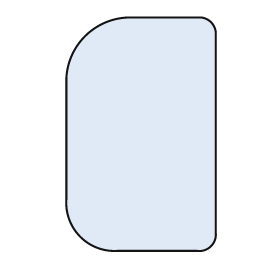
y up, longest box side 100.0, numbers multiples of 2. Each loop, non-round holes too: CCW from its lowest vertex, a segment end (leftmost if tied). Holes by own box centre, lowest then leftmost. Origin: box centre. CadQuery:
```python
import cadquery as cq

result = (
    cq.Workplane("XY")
    .moveTo(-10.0, -50.0)
    .lineTo(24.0, -50.0)
    .threePointArc((30.0, -48.0), (32.0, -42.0))
    .lineTo(32.0, 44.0)
    .threePointArc((30.0, 48.0), (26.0, 50.0))
    .lineTo(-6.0, 50.0)
    .threePointArc((-24.0, 42.0), (-32.0, 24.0))
    .lineTo(-32.0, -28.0)
    .threePointArc((-26.0, -44.0), (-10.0, -50.0))
    .close()
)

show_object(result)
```